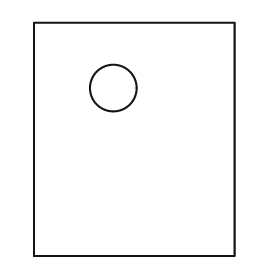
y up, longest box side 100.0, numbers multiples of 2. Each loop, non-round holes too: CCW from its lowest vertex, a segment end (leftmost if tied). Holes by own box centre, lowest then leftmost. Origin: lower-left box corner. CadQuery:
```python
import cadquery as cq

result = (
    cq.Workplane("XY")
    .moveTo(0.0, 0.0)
    .lineTo(86.0, 0.0)
    .lineTo(86.0, 100.0)
    .lineTo(0.0, 100.0)
    .close()
    .moveTo(34.0, 72.0)
    .circle(10.0)
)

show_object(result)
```